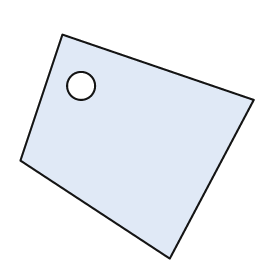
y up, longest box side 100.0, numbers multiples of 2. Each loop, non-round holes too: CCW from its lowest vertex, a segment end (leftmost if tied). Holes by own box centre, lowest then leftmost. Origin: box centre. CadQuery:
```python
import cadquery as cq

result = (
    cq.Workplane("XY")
    .moveTo(14.0, -48.0)
    .lineTo(50.0, 20.0)
    .lineTo(-32.0, 48.0)
    .lineTo(-50.0, -6.0)
    .close()
    .moveTo(-24.0, 26.0)
    .circle(6.0)
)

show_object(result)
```